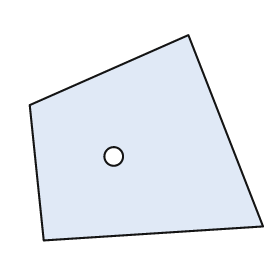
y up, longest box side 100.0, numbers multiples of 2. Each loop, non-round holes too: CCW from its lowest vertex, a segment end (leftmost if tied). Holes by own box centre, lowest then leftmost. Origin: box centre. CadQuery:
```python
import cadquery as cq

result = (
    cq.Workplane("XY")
    .moveTo(-44.0, -44.0)
    .lineTo(50.0, -38.0)
    .lineTo(18.0, 44.0)
    .lineTo(-50.0, 14.0)
    .close()
    .moveTo(-14.0, -8.0)
    .circle(4.0)
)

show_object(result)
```